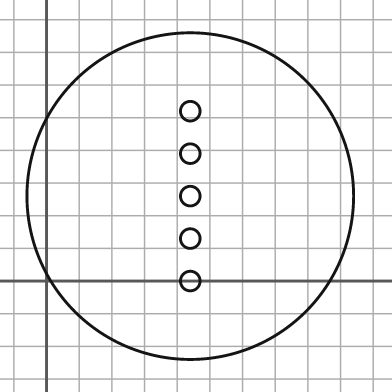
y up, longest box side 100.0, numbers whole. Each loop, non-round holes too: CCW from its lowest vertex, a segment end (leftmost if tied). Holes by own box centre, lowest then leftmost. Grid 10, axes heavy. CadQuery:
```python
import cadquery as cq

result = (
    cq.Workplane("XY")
    .moveTo(44.0, 26.0)
    .circle(50.0)
    .moveTo(44.0, 0.0)
    .circle(3.0)
    .moveTo(44.0, 13.0)
    .circle(3.0)
    .moveTo(44.0, 26.0)
    .circle(3.0)
    .moveTo(44.0, 39.0)
    .circle(3.0)
    .moveTo(44.0, 52.0)
    .circle(3.0)
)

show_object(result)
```